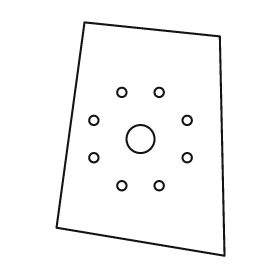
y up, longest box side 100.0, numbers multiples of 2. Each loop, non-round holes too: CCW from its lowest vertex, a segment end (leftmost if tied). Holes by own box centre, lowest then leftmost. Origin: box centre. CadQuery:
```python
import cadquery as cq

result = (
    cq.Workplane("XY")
    .moveTo(36.0, -50.0)
    .lineTo(34.0, 44.0)
    .lineTo(-24.0, 50.0)
    .lineTo(-36.0, -38.0)
    .close()
    .moveTo(-8.0, -20.0)
    .circle(2.0)
    .moveTo(8.0, -20.0)
    .circle(2.0)
    .moveTo(-20.0, -8.0)
    .circle(2.0)
    .moveTo(20.0, -8.0)
    .circle(2.0)
    .moveTo(0.0, 0.0)
    .circle(6.0)
    .moveTo(-20.0, 8.0)
    .circle(2.0)
    .moveTo(20.0, 8.0)
    .circle(2.0)
    .moveTo(-8.0, 20.0)
    .circle(2.0)
    .moveTo(8.0, 20.0)
    .circle(2.0)
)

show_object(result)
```